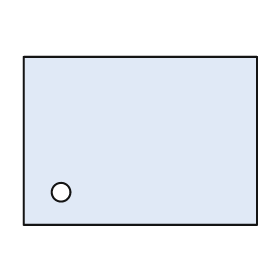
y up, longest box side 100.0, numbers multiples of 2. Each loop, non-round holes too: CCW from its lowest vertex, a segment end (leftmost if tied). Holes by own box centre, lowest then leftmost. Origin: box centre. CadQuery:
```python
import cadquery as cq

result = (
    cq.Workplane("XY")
    .moveTo(-50.0, -36.0)
    .lineTo(50.0, -36.0)
    .lineTo(50.0, 36.0)
    .lineTo(-50.0, 36.0)
    .close()
    .moveTo(-34.0, -22.0)
    .circle(4.0)
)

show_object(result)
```